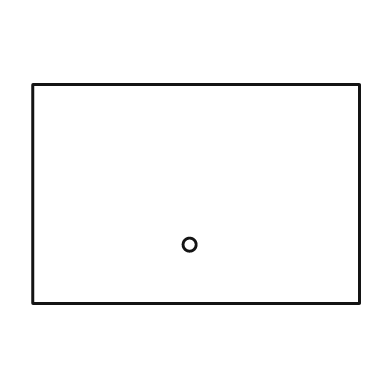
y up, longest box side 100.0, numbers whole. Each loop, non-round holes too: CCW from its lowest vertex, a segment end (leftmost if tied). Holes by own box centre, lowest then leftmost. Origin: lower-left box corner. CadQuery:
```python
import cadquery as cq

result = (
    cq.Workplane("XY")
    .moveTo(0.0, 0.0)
    .lineTo(100.0, 0.0)
    .lineTo(100.0, 67.0)
    .lineTo(0.0, 67.0)
    .close()
    .moveTo(48.0, 18.0)
    .circle(2.0)
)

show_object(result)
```